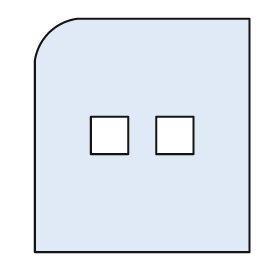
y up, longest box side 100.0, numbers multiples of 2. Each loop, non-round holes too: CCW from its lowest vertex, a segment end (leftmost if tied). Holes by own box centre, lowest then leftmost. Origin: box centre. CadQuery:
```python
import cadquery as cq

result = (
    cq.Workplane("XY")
    .moveTo(-46.0, -50.0)
    .lineTo(46.0, -50.0)
    .lineTo(46.0, 50.0)
    .lineTo(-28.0, 50.0)
    .threePointArc((-40.0, 44.0), (-46.0, 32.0))
    .close()
    .moveTo(-22.0, -8.0)
    .lineTo(-6.0, -8.0)
    .lineTo(-6.0, 8.0)
    .lineTo(-22.0, 8.0)
    .close()
    .moveTo(6.0, -8.0)
    .lineTo(22.0, -8.0)
    .lineTo(22.0, 8.0)
    .lineTo(6.0, 8.0)
    .close()
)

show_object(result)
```